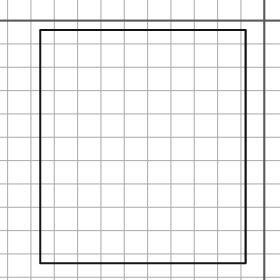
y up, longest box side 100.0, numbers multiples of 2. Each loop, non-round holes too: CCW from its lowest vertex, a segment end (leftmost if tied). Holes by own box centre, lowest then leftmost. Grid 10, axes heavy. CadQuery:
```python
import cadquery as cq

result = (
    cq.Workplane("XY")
    .moveTo(-96.0, -104.0)
    .lineTo(-8.0, -104.0)
    .lineTo(-8.0, -4.0)
    .lineTo(-96.0, -4.0)
    .close()
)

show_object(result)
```